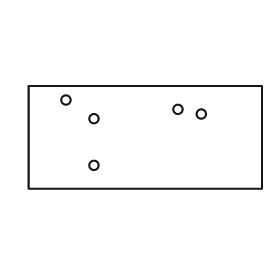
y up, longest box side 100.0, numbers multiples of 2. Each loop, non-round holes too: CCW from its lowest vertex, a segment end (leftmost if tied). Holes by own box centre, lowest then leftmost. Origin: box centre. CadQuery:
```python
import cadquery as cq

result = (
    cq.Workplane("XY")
    .moveTo(-50.0, -22.0)
    .lineTo(50.0, -22.0)
    .lineTo(50.0, 22.0)
    .lineTo(-50.0, 22.0)
    .close()
    .moveTo(-22.0, -12.0)
    .circle(2.0)
    .moveTo(-22.0, 8.0)
    .circle(2.0)
    .moveTo(24.0, 10.0)
    .circle(2.0)
    .moveTo(14.0, 12.0)
    .circle(2.0)
    .moveTo(-34.0, 16.0)
    .circle(2.0)
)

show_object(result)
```